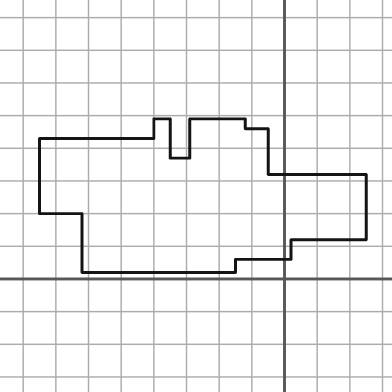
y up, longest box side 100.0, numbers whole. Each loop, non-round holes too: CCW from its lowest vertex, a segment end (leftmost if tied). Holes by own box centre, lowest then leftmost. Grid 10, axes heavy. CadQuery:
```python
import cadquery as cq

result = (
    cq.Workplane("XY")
    .moveTo(-62.0, 2.0)
    .lineTo(-15.0, 2.0)
    .lineTo(-15.0, 6.0)
    .lineTo(2.0, 6.0)
    .lineTo(2.0, 12.0)
    .lineTo(25.0, 12.0)
    .lineTo(25.0, 32.0)
    .lineTo(-5.0, 32.0)
    .lineTo(-5.0, 46.0)
    .lineTo(-12.0, 46.0)
    .lineTo(-12.0, 49.0)
    .lineTo(-29.0, 49.0)
    .lineTo(-29.0, 37.0)
    .lineTo(-35.0, 37.0)
    .lineTo(-35.0, 49.0)
    .lineTo(-40.0, 49.0)
    .lineTo(-40.0, 43.0)
    .lineTo(-75.0, 43.0)
    .lineTo(-75.0, 20.0)
    .lineTo(-62.0, 20.0)
    .close()
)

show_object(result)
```